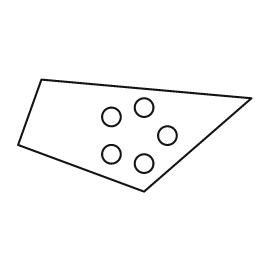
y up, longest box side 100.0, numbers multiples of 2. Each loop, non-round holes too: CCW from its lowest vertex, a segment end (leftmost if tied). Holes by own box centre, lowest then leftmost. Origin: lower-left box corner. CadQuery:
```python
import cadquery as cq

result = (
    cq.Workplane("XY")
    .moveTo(54.0, 0.0)
    .lineTo(100.0, 40.0)
    .lineTo(10.0, 48.0)
    .lineTo(0.0, 20.0)
    .close()
    .moveTo(54.0, 12.0)
    .circle(4.0)
    .moveTo(40.0, 16.0)
    .circle(4.0)
    .moveTo(64.0, 24.0)
    .circle(4.0)
    .moveTo(40.0, 32.0)
    .circle(4.0)
    .moveTo(54.0, 36.0)
    .circle(4.0)
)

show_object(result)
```